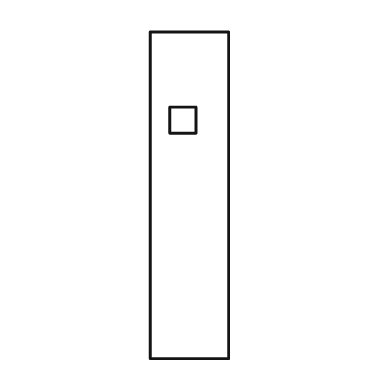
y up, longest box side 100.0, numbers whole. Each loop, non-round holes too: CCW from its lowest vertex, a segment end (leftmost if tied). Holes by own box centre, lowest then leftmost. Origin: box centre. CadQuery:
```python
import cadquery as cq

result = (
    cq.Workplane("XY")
    .moveTo(-12.0, -50.0)
    .lineTo(12.0, -50.0)
    .lineTo(12.0, 50.0)
    .lineTo(-12.0, 50.0)
    .close()
    .moveTo(-6.0, 19.0)
    .lineTo(2.0, 19.0)
    .lineTo(2.0, 27.0)
    .lineTo(-6.0, 27.0)
    .close()
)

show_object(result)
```